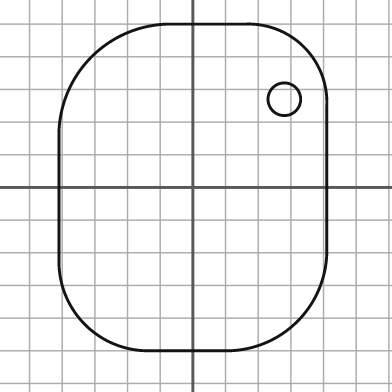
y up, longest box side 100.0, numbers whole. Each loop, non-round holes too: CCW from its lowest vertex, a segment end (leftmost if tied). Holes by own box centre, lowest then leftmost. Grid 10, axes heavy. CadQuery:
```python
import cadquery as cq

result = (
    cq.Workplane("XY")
    .moveTo(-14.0, -50.0)
    .lineTo(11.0, -50.0)
    .threePointArc((32.0, -41.0), (41.0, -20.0))
    .lineTo(41.0, 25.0)
    .threePointArc((34.0, 43.0), (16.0, 50.0))
    .lineTo(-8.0, 50.0)
    .threePointArc((-31.0, 40.0), (-41.0, 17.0))
    .lineTo(-41.0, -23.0)
    .threePointArc((-33.0, -42.0), (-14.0, -50.0))
    .close()
    .moveTo(28.0, 27.0)
    .circle(5.0)
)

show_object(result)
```